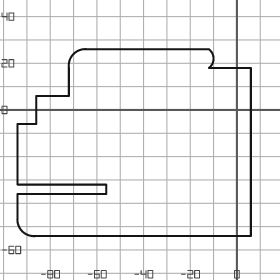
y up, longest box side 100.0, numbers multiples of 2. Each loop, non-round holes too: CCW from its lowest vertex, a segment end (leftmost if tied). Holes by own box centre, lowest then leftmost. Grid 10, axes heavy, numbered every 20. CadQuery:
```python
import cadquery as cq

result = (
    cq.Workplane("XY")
    .moveTo(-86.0, -54.0)
    .lineTo(6.0, -54.0)
    .lineTo(6.0, 18.0)
    .lineTo(-12.0, 18.0)
    .threePointArc((-10.0, 22.0), (-12.0, 26.0))
    .lineTo(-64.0, 26.0)
    .threePointArc((-70.0, 24.0), (-72.0, 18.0))
    .lineTo(-72.0, 6.0)
    .lineTo(-86.0, 6.0)
    .lineTo(-86.0, -6.0)
    .lineTo(-94.0, -6.0)
    .lineTo(-94.0, -32.0)
    .lineTo(-56.0, -32.0)
    .lineTo(-56.0, -36.0)
    .lineTo(-94.0, -36.0)
    .lineTo(-94.0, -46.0)
    .threePointArc((-92.0, -52.0), (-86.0, -54.0))
    .close()
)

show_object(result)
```